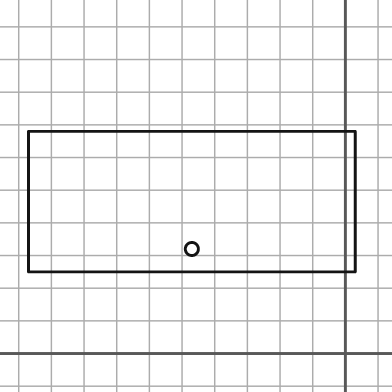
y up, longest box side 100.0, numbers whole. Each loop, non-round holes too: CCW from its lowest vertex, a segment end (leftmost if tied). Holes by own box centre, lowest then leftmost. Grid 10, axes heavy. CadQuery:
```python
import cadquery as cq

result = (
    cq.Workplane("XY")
    .moveTo(-97.0, 25.0)
    .lineTo(3.0, 25.0)
    .lineTo(3.0, 68.0)
    .lineTo(-97.0, 68.0)
    .close()
    .moveTo(-47.0, 32.0)
    .circle(2.0)
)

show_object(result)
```